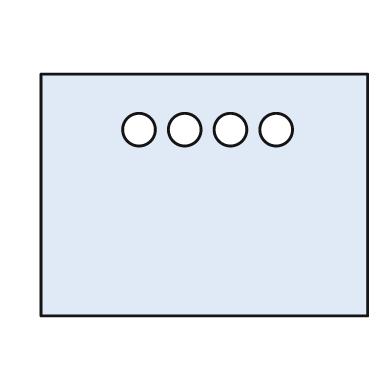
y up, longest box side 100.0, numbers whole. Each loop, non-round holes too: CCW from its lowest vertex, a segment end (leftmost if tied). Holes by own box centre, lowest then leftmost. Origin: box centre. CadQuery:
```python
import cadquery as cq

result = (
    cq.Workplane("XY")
    .moveTo(-50.0, -37.0)
    .lineTo(50.0, -37.0)
    .lineTo(50.0, 37.0)
    .lineTo(-50.0, 37.0)
    .close()
    .moveTo(-20.0, 20.0)
    .circle(5.0)
    .moveTo(-6.0, 20.0)
    .circle(5.0)
    .moveTo(8.0, 20.0)
    .circle(5.0)
    .moveTo(22.0, 20.0)
    .circle(5.0)
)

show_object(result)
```